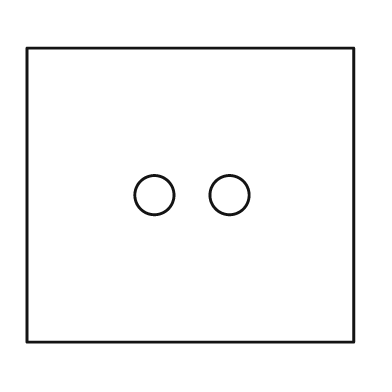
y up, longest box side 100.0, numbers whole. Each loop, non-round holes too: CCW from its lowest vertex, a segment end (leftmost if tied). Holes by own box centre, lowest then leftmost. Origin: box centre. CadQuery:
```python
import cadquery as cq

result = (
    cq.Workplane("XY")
    .moveTo(-50.0, -45.0)
    .lineTo(50.0, -45.0)
    .lineTo(50.0, 45.0)
    .lineTo(-50.0, 45.0)
    .close()
    .moveTo(-11.0, 0.0)
    .circle(6.0)
    .moveTo(12.0, 0.0)
    .circle(6.0)
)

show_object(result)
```